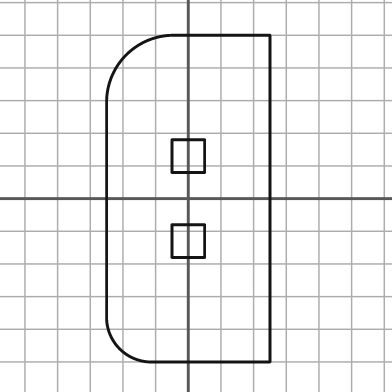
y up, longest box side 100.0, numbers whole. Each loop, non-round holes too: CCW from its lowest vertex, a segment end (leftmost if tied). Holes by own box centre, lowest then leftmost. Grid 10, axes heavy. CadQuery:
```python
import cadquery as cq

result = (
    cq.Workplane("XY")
    .moveTo(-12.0, -50.0)
    .lineTo(25.0, -50.0)
    .lineTo(25.0, 50.0)
    .lineTo(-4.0, 50.0)
    .threePointArc((-19.0, 44.0), (-25.0, 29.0))
    .lineTo(-25.0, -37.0)
    .threePointArc((-21.0, -46.0), (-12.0, -50.0))
    .close()
    .moveTo(-5.0, -18.0)
    .lineTo(5.0, -18.0)
    .lineTo(5.0, -8.0)
    .lineTo(-5.0, -8.0)
    .close()
    .moveTo(-5.0, 8.0)
    .lineTo(5.0, 8.0)
    .lineTo(5.0, 18.0)
    .lineTo(-5.0, 18.0)
    .close()
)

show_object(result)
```